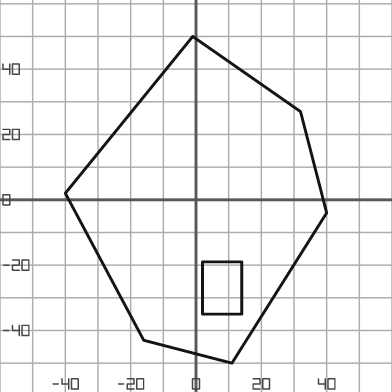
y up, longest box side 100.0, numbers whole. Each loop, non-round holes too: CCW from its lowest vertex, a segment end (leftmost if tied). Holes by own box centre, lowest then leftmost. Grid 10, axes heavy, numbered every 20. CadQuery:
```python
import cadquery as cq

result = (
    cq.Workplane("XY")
    .moveTo(11.0, -50.0)
    .lineTo(40.0, -4.0)
    .lineTo(32.0, 27.0)
    .lineTo(-1.0, 50.0)
    .lineTo(-40.0, 2.0)
    .lineTo(-16.0, -43.0)
    .close()
    .moveTo(2.0, -35.0)
    .lineTo(14.0, -35.0)
    .lineTo(14.0, -19.0)
    .lineTo(2.0, -19.0)
    .close()
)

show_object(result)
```